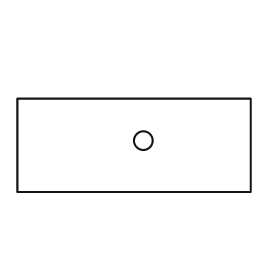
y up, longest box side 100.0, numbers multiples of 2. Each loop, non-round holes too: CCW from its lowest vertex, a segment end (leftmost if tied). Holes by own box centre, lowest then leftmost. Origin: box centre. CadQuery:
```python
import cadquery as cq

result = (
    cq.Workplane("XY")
    .moveTo(-50.0, -20.0)
    .lineTo(50.0, -20.0)
    .lineTo(50.0, 20.0)
    .lineTo(-50.0, 20.0)
    .close()
    .moveTo(4.0, 2.0)
    .circle(4.0)
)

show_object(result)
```